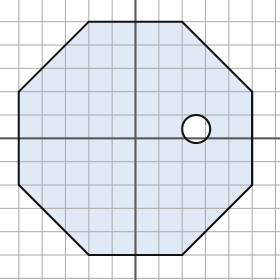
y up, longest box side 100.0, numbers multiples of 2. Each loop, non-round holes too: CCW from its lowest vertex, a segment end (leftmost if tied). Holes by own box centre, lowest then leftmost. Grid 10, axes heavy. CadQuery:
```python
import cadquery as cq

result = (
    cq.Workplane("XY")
    .moveTo(-20.0, -50.0)
    .lineTo(20.0, -50.0)
    .lineTo(50.0, -20.0)
    .lineTo(50.0, 20.0)
    .lineTo(20.0, 50.0)
    .lineTo(-20.0, 50.0)
    .lineTo(-50.0, 20.0)
    .lineTo(-50.0, -20.0)
    .close()
    .moveTo(26.0, 4.0)
    .circle(6.0)
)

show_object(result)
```